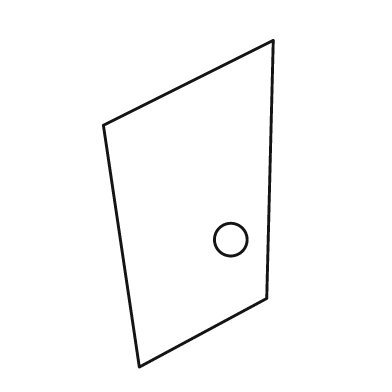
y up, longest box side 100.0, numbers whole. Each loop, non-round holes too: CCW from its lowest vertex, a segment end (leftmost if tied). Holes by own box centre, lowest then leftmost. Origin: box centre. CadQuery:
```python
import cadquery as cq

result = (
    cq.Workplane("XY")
    .moveTo(-15.0, -50.0)
    .lineTo(24.0, -29.0)
    .lineTo(26.0, 50.0)
    .lineTo(-26.0, 24.0)
    .close()
    .moveTo(13.0, -11.0)
    .circle(5.0)
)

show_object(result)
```